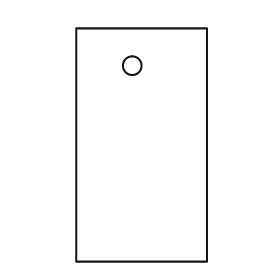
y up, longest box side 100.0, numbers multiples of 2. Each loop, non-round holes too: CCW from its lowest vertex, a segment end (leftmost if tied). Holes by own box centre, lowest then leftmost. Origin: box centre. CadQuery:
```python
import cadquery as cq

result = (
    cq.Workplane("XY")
    .moveTo(-28.0, -50.0)
    .lineTo(28.0, -50.0)
    .lineTo(28.0, 50.0)
    .lineTo(-28.0, 50.0)
    .close()
    .moveTo(-4.0, 34.0)
    .circle(4.0)
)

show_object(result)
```